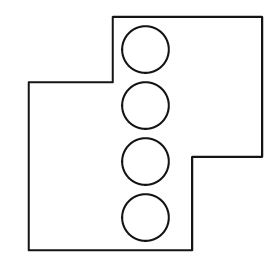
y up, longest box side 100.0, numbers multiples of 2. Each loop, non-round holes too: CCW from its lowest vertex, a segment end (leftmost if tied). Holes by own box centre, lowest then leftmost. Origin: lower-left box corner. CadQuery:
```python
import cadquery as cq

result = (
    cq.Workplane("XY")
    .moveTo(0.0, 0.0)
    .lineTo(70.0, 0.0)
    .lineTo(70.0, 40.0)
    .lineTo(100.0, 40.0)
    .lineTo(100.0, 100.0)
    .lineTo(36.0, 100.0)
    .lineTo(36.0, 72.0)
    .lineTo(0.0, 72.0)
    .close()
    .moveTo(50.0, 14.0)
    .circle(10.0)
    .moveTo(50.0, 38.0)
    .circle(10.0)
    .moveTo(50.0, 62.0)
    .circle(10.0)
    .moveTo(50.0, 86.0)
    .circle(10.0)
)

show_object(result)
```